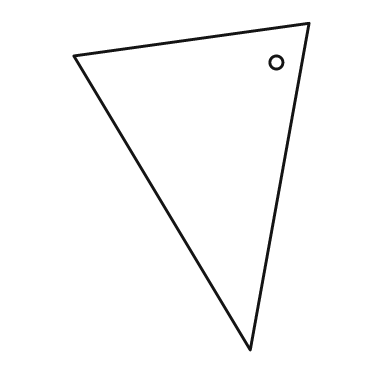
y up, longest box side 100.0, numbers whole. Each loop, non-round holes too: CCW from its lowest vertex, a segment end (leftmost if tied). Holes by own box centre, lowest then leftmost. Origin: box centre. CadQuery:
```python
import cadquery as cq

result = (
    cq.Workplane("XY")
    .moveTo(18.0, -50.0)
    .lineTo(36.0, 50.0)
    .lineTo(-36.0, 40.0)
    .close()
    .moveTo(26.0, 38.0)
    .circle(2.0)
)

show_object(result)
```